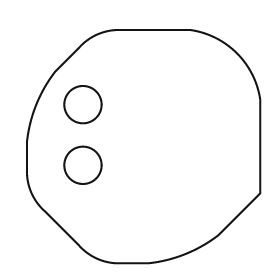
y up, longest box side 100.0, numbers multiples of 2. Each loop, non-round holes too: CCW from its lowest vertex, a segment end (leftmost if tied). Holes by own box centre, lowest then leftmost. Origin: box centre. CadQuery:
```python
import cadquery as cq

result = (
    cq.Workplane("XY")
    .moveTo(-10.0, -50.0)
    .lineTo(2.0, -50.0)
    .threePointArc((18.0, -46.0), (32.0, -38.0))
    .lineTo(50.0, -20.0)
    .lineTo(50.0, 20.0)
    .threePointArc((40.0, 40.0), (20.0, 50.0))
    .lineTo(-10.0, 50.0)
    .threePointArc((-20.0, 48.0), (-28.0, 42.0))
    .lineTo(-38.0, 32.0)
    .threePointArc((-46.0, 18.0), (-50.0, 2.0))
    .lineTo(-50.0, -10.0)
    .threePointArc((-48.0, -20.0), (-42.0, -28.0))
    .lineTo(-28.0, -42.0)
    .threePointArc((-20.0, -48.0), (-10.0, -50.0))
    .close()
    .moveTo(-26.0, -8.0)
    .circle(8.0)
    .moveTo(-26.0, 18.0)
    .circle(8.0)
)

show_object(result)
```